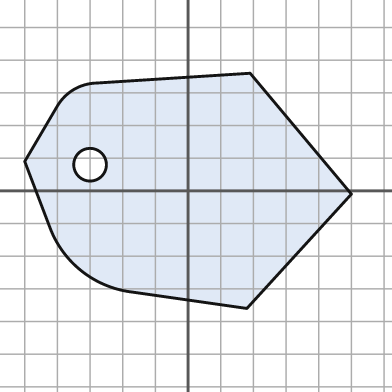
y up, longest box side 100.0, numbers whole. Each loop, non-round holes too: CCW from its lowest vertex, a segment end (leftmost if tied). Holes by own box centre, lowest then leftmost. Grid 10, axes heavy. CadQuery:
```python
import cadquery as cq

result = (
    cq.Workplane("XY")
    .moveTo(18.0, -36.0)
    .lineTo(50.0, -1.0)
    .lineTo(19.0, 36.0)
    .lineTo(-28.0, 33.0)
    .threePointArc((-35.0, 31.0), (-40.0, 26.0))
    .lineTo(-50.0, 9.0)
    .lineTo(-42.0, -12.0)
    .threePointArc((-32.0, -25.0), (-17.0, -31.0))
    .close()
    .moveTo(-30.0, 8.0)
    .circle(5.0)
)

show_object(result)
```